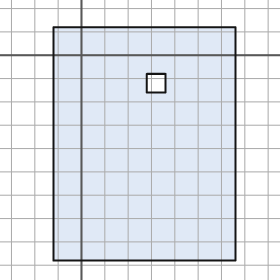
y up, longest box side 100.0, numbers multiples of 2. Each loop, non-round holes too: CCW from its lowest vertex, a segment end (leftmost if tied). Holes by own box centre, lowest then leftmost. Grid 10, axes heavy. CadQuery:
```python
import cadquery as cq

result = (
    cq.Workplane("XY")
    .moveTo(-12.0, -88.0)
    .lineTo(66.0, -88.0)
    .lineTo(66.0, 12.0)
    .lineTo(-12.0, 12.0)
    .close()
    .moveTo(28.0, -16.0)
    .lineTo(36.0, -16.0)
    .lineTo(36.0, -8.0)
    .lineTo(28.0, -8.0)
    .close()
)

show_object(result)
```